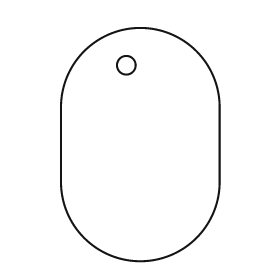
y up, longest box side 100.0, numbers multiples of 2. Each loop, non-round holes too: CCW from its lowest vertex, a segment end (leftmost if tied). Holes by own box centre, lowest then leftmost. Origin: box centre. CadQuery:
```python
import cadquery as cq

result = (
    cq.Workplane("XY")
    .moveTo(-34.0, -16.0)
    .threePointArc((0.0, -50.0), (34.0, -16.0))
    .lineTo(34.0, 16.0)
    .threePointArc((0.0, 50.0), (-34.0, 16.0))
    .close()
    .moveTo(-6.0, 34.0)
    .circle(4.0)
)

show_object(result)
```